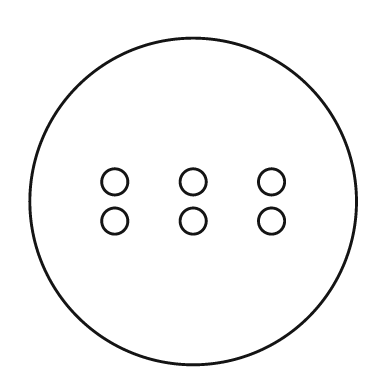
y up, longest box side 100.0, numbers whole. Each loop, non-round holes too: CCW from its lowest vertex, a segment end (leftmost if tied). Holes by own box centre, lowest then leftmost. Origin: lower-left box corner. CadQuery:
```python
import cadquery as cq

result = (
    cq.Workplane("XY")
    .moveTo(50.0, 50.0)
    .circle(50.0)
    .moveTo(26.0, 44.0)
    .circle(4.0)
    .moveTo(50.0, 44.0)
    .circle(4.0)
    .moveTo(74.0, 44.0)
    .circle(4.0)
    .moveTo(26.0, 56.0)
    .circle(4.0)
    .moveTo(50.0, 56.0)
    .circle(4.0)
    .moveTo(74.0, 56.0)
    .circle(4.0)
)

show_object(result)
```